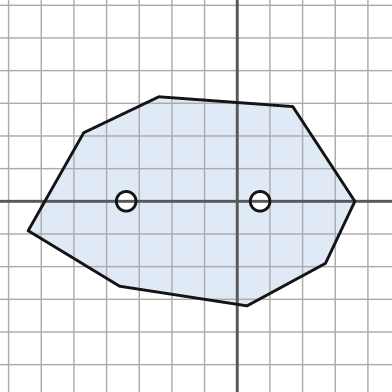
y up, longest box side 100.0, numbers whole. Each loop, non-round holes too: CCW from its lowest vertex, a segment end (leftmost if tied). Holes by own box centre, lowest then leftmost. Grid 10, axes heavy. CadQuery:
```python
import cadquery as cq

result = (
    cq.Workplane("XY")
    .moveTo(3.0, -32.0)
    .lineTo(27.0, -19.0)
    .lineTo(36.0, 0.0)
    .lineTo(17.0, 29.0)
    .lineTo(-24.0, 32.0)
    .lineTo(-47.0, 21.0)
    .lineTo(-64.0, -9.0)
    .lineTo(-36.0, -26.0)
    .close()
    .moveTo(-34.0, 0.0)
    .circle(3.0)
    .moveTo(7.0, 0.0)
    .circle(3.0)
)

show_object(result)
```